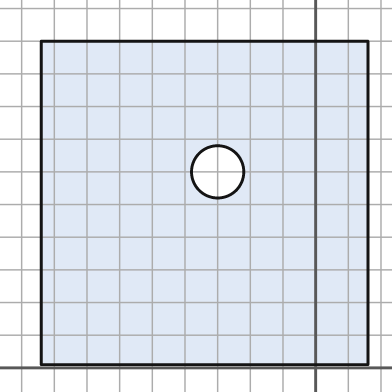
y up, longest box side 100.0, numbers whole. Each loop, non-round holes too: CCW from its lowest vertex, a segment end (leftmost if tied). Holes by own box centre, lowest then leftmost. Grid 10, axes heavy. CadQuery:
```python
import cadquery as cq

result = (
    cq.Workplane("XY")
    .moveTo(-84.0, 1.0)
    .lineTo(16.0, 1.0)
    .lineTo(16.0, 100.0)
    .lineTo(-84.0, 100.0)
    .close()
    .moveTo(-30.0, 60.0)
    .circle(8.0)
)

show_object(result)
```